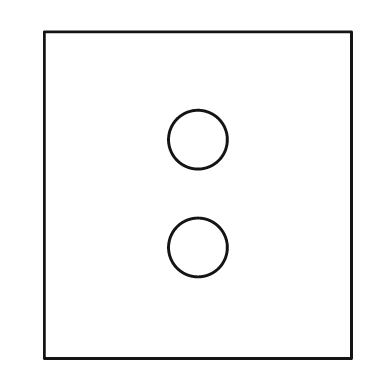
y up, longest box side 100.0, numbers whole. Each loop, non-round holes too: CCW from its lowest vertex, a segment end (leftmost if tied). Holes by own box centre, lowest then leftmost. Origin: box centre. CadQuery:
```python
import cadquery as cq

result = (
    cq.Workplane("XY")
    .moveTo(-47.0, -50.0)
    .lineTo(47.0, -50.0)
    .lineTo(47.0, 50.0)
    .lineTo(-47.0, 50.0)
    .close()
    .moveTo(0.0, -16.0)
    .circle(9.0)
    .moveTo(0.0, 17.0)
    .circle(9.0)
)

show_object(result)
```